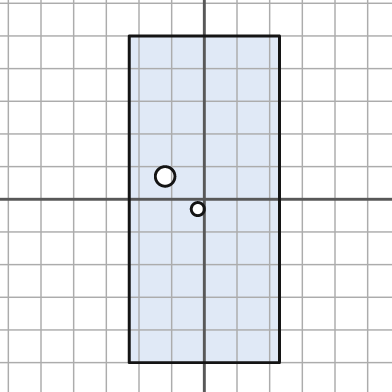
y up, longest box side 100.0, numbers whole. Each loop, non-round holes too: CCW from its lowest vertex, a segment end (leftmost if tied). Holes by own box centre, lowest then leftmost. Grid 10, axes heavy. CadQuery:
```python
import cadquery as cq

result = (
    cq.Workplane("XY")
    .moveTo(-23.0, -50.0)
    .lineTo(23.0, -50.0)
    .lineTo(23.0, 50.0)
    .lineTo(-23.0, 50.0)
    .close()
    .moveTo(-2.0, -3.0)
    .circle(2.0)
    .moveTo(-12.0, 7.0)
    .circle(3.0)
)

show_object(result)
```